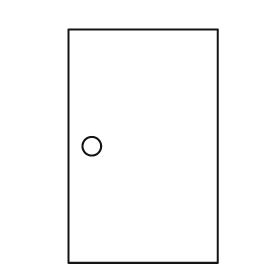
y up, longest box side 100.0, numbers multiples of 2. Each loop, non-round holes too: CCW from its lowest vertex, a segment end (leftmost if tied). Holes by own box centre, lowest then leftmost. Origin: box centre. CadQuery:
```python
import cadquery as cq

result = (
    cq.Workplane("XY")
    .moveTo(-32.0, -50.0)
    .lineTo(32.0, -50.0)
    .lineTo(32.0, 50.0)
    .lineTo(-32.0, 50.0)
    .close()
    .moveTo(-22.0, 0.0)
    .circle(4.0)
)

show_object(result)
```